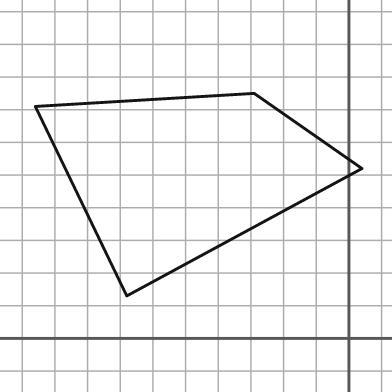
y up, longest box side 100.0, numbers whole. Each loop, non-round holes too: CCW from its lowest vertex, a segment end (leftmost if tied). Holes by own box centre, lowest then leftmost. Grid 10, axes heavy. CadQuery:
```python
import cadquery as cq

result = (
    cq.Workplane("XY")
    .moveTo(-68.0, 13.0)
    .lineTo(4.0, 52.0)
    .lineTo(-29.0, 75.0)
    .lineTo(-96.0, 71.0)
    .close()
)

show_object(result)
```